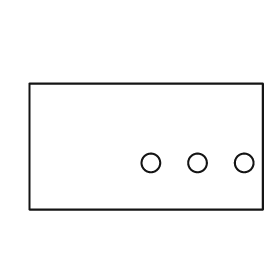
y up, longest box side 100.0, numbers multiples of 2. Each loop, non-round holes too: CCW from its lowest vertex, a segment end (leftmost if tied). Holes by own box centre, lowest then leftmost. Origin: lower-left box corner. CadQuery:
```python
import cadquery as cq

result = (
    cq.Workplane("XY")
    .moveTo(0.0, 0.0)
    .lineTo(100.0, 0.0)
    .lineTo(100.0, 54.0)
    .lineTo(0.0, 54.0)
    .close()
    .moveTo(52.0, 20.0)
    .circle(4.0)
    .moveTo(72.0, 20.0)
    .circle(4.0)
    .moveTo(92.0, 20.0)
    .circle(4.0)
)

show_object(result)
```